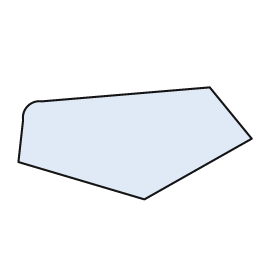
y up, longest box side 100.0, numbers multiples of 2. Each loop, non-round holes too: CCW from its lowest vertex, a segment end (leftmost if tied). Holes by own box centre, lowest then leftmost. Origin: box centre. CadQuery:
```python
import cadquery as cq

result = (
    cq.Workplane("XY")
    .moveTo(4.0, -24.0)
    .lineTo(50.0, 2.0)
    .lineTo(32.0, 24.0)
    .lineTo(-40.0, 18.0)
    .threePointArc((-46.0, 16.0), (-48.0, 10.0))
    .lineTo(-50.0, -8.0)
    .close()
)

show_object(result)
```